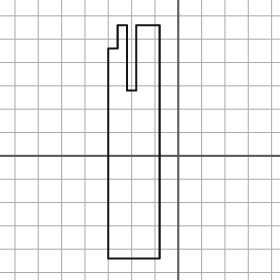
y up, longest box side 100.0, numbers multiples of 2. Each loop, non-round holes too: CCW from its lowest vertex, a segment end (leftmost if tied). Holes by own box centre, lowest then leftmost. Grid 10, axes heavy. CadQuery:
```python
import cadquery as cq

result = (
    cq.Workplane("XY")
    .moveTo(-30.0, -44.0)
    .lineTo(-8.0, -44.0)
    .lineTo(-8.0, 56.0)
    .lineTo(-18.0, 56.0)
    .lineTo(-18.0, 28.0)
    .lineTo(-22.0, 28.0)
    .lineTo(-22.0, 56.0)
    .lineTo(-26.0, 56.0)
    .lineTo(-26.0, 46.0)
    .lineTo(-30.0, 46.0)
    .close()
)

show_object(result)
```